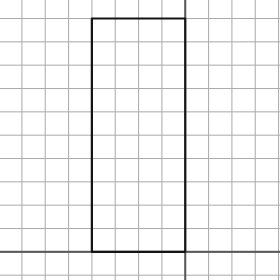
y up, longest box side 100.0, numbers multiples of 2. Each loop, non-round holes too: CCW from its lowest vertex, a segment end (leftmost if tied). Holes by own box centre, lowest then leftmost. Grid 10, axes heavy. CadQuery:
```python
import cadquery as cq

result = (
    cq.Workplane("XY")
    .moveTo(-40.0, 0.0)
    .lineTo(0.0, 0.0)
    .lineTo(0.0, 100.0)
    .lineTo(-40.0, 100.0)
    .close()
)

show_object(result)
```